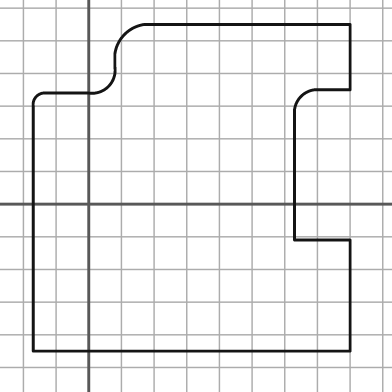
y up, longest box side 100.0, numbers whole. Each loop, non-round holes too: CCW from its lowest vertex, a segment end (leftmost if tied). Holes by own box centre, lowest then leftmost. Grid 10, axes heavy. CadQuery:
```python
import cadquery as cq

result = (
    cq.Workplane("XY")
    .moveTo(-17.0, -45.0)
    .lineTo(80.0, -45.0)
    .lineTo(80.0, -11.0)
    .lineTo(63.0, -11.0)
    .lineTo(63.0, 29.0)
    .threePointArc((65.0, 33.0), (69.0, 35.0))
    .lineTo(80.0, 35.0)
    .lineTo(80.0, 55.0)
    .lineTo(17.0, 55.0)
    .threePointArc((11.0, 52.0), (8.0, 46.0))
    .lineTo(8.0, 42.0)
    .threePointArc((6.0, 36.0), (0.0, 34.0))
    .lineTo(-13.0, 34.0)
    .threePointArc((-16.0, 33.0), (-17.0, 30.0))
    .close()
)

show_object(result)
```